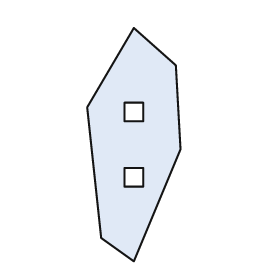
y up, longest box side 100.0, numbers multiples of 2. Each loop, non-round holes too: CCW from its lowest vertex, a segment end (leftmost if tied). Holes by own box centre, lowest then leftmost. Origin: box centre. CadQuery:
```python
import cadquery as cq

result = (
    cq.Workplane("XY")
    .moveTo(0.0, -50.0)
    .lineTo(20.0, -2.0)
    .lineTo(18.0, 34.0)
    .lineTo(0.0, 50.0)
    .lineTo(-20.0, 16.0)
    .lineTo(-14.0, -40.0)
    .close()
    .moveTo(-4.0, -18.0)
    .lineTo(4.0, -18.0)
    .lineTo(4.0, -10.0)
    .lineTo(-4.0, -10.0)
    .close()
    .moveTo(-4.0, 10.0)
    .lineTo(4.0, 10.0)
    .lineTo(4.0, 18.0)
    .lineTo(-4.0, 18.0)
    .close()
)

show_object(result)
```